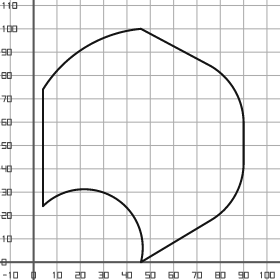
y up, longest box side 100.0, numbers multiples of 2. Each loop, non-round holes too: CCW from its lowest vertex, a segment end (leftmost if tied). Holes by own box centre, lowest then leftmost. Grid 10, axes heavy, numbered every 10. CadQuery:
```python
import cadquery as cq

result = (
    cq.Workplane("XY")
    .moveTo(46.0, 0.0)
    .lineTo(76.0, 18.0)
    .threePointArc((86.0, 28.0), (90.0, 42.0))
    .lineTo(90.0, 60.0)
    .threePointArc((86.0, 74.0), (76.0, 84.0))
    .lineTo(46.0, 100.0)
    .threePointArc((22.0, 92.0), (4.0, 74.0))
    .lineTo(4.0, 24.0)
    .threePointArc((34.0, 28.0), (46.0, 0.0))
    .close()
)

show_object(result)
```